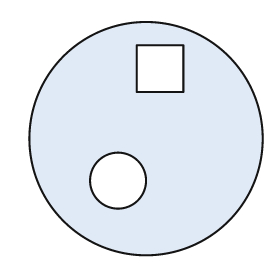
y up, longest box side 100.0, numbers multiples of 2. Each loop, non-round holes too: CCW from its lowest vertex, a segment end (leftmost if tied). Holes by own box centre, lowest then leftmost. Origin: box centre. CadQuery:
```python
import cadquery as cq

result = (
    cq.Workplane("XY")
    .moveTo(0.0, 0.0)
    .circle(50.0)
    .moveTo(-12.0, -18.0)
    .circle(12.0)
    .moveTo(-4.0, 20.0)
    .lineTo(16.0, 20.0)
    .lineTo(16.0, 40.0)
    .lineTo(-4.0, 40.0)
    .close()
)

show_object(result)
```